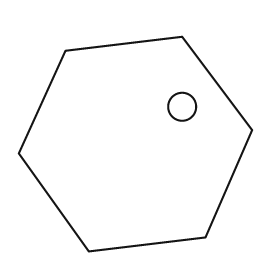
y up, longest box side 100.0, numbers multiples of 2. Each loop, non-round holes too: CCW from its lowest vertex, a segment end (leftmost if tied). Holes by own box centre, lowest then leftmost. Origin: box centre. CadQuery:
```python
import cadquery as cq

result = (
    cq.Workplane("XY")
    .moveTo(-20.0, -46.0)
    .lineTo(30.0, -40.0)
    .lineTo(50.0, 6.0)
    .lineTo(20.0, 46.0)
    .lineTo(-30.0, 40.0)
    .lineTo(-50.0, -4.0)
    .close()
    .moveTo(20.0, 16.0)
    .circle(6.0)
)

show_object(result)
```